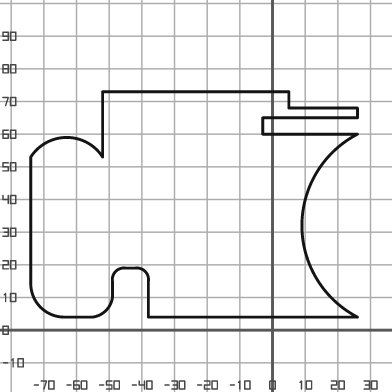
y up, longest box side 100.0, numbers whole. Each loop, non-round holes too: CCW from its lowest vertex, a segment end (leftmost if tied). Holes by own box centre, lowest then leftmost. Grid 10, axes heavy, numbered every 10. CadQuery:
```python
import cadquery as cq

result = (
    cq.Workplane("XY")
    .moveTo(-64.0, 4.0)
    .lineTo(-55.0, 4.0)
    .threePointArc((-51.0, 6.0), (-49.0, 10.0))
    .lineTo(-49.0, 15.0)
    .threePointArc((-48.0, 18.0), (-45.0, 19.0))
    .lineTo(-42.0, 19.0)
    .threePointArc((-39.0, 18.0), (-38.0, 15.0))
    .lineTo(-38.0, 4.0)
    .lineTo(26.0, 4.0)
    .threePointArc((9.0, 32.0), (26.0, 60.0))
    .lineTo(-3.0, 60.0)
    .lineTo(-3.0, 65.0)
    .lineTo(26.0, 65.0)
    .lineTo(26.0, 68.0)
    .lineTo(5.0, 68.0)
    .lineTo(5.0, 73.0)
    .lineTo(-52.0, 73.0)
    .lineTo(-52.0, 53.0)
    .threePointArc((-63.0, 59.0), (-74.0, 53.0))
    .lineTo(-74.0, 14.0)
    .threePointArc((-71.0, 7.0), (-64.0, 4.0))
    .close()
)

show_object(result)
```